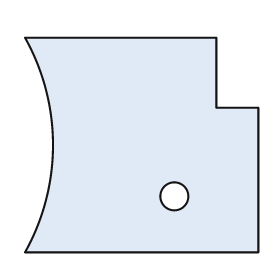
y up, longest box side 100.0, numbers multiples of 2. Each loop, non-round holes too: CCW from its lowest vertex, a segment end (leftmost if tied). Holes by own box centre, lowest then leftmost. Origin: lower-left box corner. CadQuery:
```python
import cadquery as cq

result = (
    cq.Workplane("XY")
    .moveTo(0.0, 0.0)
    .lineTo(100.0, 0.0)
    .lineTo(100.0, 62.0)
    .lineTo(82.0, 62.0)
    .lineTo(82.0, 92.0)
    .lineTo(0.0, 92.0)
    .threePointArc((12.0, 46.0), (0.0, 0.0))
    .close()
    .moveTo(64.0, 24.0)
    .circle(6.0)
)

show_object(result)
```